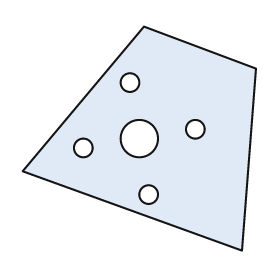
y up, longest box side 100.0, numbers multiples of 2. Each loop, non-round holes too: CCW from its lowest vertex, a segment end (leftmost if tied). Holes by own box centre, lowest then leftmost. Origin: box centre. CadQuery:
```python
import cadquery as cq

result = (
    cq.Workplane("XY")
    .moveTo(44.0, -48.0)
    .lineTo(50.0, 30.0)
    .lineTo(2.0, 48.0)
    .lineTo(-50.0, -14.0)
    .close()
    .moveTo(4.0, -24.0)
    .circle(4.0)
    .moveTo(-24.0, -4.0)
    .circle(4.0)
    .moveTo(0.0, 0.0)
    .circle(8.0)
    .moveTo(24.0, 4.0)
    .circle(4.0)
    .moveTo(-4.0, 24.0)
    .circle(4.0)
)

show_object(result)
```